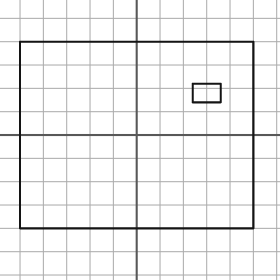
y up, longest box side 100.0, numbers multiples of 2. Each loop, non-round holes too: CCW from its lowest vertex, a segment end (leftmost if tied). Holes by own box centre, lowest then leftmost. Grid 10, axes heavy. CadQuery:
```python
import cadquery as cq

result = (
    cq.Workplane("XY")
    .moveTo(-50.0, -40.0)
    .lineTo(50.0, -40.0)
    .lineTo(50.0, 40.0)
    .lineTo(-50.0, 40.0)
    .close()
    .moveTo(24.0, 14.0)
    .lineTo(36.0, 14.0)
    .lineTo(36.0, 22.0)
    .lineTo(24.0, 22.0)
    .close()
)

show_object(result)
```